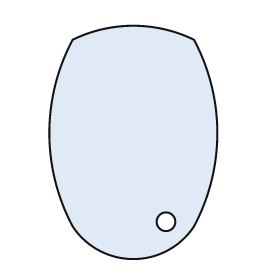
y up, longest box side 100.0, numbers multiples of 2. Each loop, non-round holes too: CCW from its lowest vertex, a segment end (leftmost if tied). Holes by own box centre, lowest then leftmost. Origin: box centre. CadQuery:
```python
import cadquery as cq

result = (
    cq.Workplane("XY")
    .moveTo(-26.0, -36.0)
    .threePointArc((0.0, -50.0), (26.0, -36.0))
    .threePointArc((36.0, 4.0), (26.0, 44.0))
    .threePointArc((0.0, 50.0), (-26.0, 44.0))
    .threePointArc((-36.0, 4.0), (-26.0, -36.0))
    .close()
    .moveTo(14.0, -34.0)
    .circle(4.0)
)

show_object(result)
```